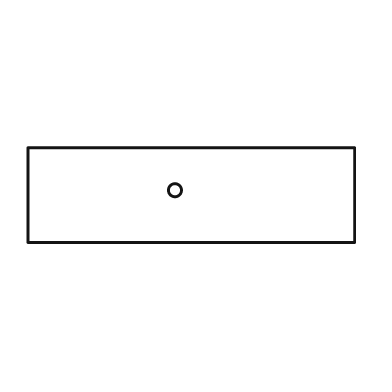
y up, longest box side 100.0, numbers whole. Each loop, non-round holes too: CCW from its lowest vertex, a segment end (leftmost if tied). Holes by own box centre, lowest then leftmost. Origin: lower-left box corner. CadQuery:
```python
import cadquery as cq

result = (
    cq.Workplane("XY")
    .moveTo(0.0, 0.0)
    .lineTo(100.0, 0.0)
    .lineTo(100.0, 29.0)
    .lineTo(0.0, 29.0)
    .close()
    .moveTo(45.0, 16.0)
    .circle(2.0)
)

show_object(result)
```